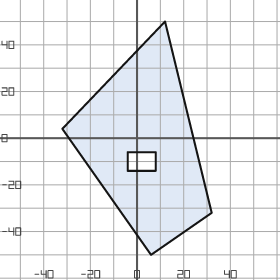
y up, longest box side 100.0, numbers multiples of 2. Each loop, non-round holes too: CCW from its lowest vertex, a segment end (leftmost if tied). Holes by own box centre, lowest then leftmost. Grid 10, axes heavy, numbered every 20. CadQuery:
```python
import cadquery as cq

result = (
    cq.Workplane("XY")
    .moveTo(6.0, -50.0)
    .lineTo(32.0, -32.0)
    .lineTo(12.0, 50.0)
    .lineTo(-32.0, 4.0)
    .close()
    .moveTo(-4.0, -14.0)
    .lineTo(8.0, -14.0)
    .lineTo(8.0, -6.0)
    .lineTo(-4.0, -6.0)
    .close()
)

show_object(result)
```